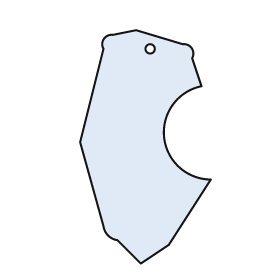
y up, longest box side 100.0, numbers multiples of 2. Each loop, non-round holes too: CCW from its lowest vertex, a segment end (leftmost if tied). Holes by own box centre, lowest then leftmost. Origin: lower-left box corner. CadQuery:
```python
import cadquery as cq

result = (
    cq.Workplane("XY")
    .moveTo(26.0, 0.0)
    .lineTo(38.0, 8.0)
    .lineTo(56.0, 36.0)
    .threePointArc((36.0, 54.0), (52.0, 76.0))
    .lineTo(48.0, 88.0)
    .threePointArc((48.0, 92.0), (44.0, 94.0))
    .lineTo(24.0, 100.0)
    .lineTo(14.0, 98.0)
    .threePointArc((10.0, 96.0), (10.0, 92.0))
    .lineTo(0.0, 52.0)
    .lineTo(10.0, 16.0)
    .threePointArc((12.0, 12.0), (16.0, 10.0))
    .close()
    .moveTo(30.0, 92.0)
    .circle(2.0)
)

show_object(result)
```